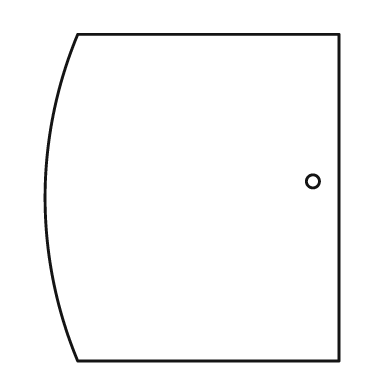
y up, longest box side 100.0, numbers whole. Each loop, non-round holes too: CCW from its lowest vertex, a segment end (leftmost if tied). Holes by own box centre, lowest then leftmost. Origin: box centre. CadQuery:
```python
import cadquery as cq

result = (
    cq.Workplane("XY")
    .moveTo(-35.0, -50.0)
    .lineTo(45.0, -50.0)
    .lineTo(45.0, 50.0)
    .lineTo(-35.0, 50.0)
    .threePointArc((-45.0, 0.0), (-35.0, -50.0))
    .close()
    .moveTo(37.0, 5.0)
    .circle(2.0)
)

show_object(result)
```